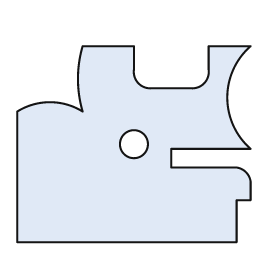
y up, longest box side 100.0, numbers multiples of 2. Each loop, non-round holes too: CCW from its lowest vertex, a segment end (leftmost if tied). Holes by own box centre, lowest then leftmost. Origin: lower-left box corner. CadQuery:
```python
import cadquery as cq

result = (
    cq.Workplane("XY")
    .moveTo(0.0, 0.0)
    .lineTo(94.0, 0.0)
    .lineTo(94.0, 18.0)
    .lineTo(100.0, 18.0)
    .lineTo(100.0, 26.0)
    .threePointArc((98.0, 30.0), (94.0, 32.0))
    .lineTo(66.0, 32.0)
    .lineTo(66.0, 40.0)
    .lineTo(100.0, 40.0)
    .threePointArc((90.0, 62.0), (100.0, 84.0))
    .lineTo(82.0, 84.0)
    .lineTo(82.0, 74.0)
    .threePointArc((80.0, 68.0), (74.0, 66.0))
    .lineTo(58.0, 66.0)
    .threePointArc((52.0, 68.0), (50.0, 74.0))
    .lineTo(50.0, 84.0)
    .lineTo(28.0, 84.0)
    .threePointArc((26.0, 70.0), (28.0, 56.0))
    .threePointArc((14.0, 60.0), (0.0, 56.0))
    .close()
    .moveTo(50.0, 42.0)
    .circle(6.0)
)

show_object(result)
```